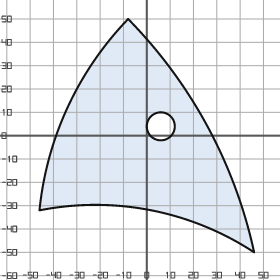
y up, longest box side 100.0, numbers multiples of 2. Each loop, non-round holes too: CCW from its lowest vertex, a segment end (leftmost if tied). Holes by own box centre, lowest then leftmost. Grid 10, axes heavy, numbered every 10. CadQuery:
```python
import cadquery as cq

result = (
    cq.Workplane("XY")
    .moveTo(46.0, -50.0)
    .threePointArc((26.0, 4.0), (-8.0, 50.0))
    .threePointArc((-34.0, 12.0), (-46.0, -32.0))
    .threePointArc((2.0, -32.0), (46.0, -50.0))
    .close()
    .moveTo(6.0, 4.0)
    .circle(6.0)
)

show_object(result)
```